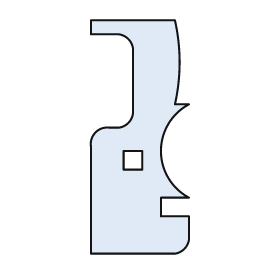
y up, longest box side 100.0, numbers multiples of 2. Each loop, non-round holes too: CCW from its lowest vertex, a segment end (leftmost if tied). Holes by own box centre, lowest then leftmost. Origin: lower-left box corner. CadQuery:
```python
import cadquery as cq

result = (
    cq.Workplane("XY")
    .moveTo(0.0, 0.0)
    .lineTo(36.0, 0.0)
    .threePointArc((40.0, 2.0), (42.0, 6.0))
    .lineTo(42.0, 16.0)
    .lineTo(30.0, 16.0)
    .lineTo(30.0, 24.0)
    .lineTo(42.0, 24.0)
    .threePointArc((30.0, 44.0), (42.0, 64.0))
    .lineTo(36.0, 64.0)
    .threePointArc((38.0, 82.0), (36.0, 100.0))
    .lineTo(0.0, 100.0)
    .lineTo(0.0, 94.0)
    .lineTo(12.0, 94.0)
    .threePointArc((16.0, 92.0), (18.0, 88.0))
    .lineTo(18.0, 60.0)
    .threePointArc((16.0, 56.0), (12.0, 54.0))
    .lineTo(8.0, 54.0)
    .threePointArc((2.0, 52.0), (0.0, 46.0))
    .close()
    .moveTo(14.0, 36.0)
    .lineTo(22.0, 36.0)
    .lineTo(22.0, 44.0)
    .lineTo(14.0, 44.0)
    .close()
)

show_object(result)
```